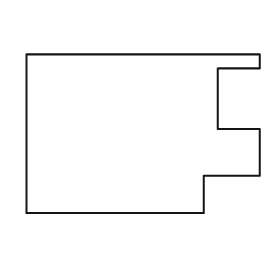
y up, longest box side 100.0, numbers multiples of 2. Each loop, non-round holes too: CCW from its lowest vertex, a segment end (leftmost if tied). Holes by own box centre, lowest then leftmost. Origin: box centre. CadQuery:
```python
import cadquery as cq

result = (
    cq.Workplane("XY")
    .moveTo(-50.0, -34.0)
    .lineTo(26.0, -34.0)
    .lineTo(26.0, -18.0)
    .lineTo(50.0, -18.0)
    .lineTo(50.0, 2.0)
    .lineTo(32.0, 2.0)
    .lineTo(32.0, 28.0)
    .lineTo(50.0, 28.0)
    .lineTo(50.0, 34.0)
    .lineTo(-50.0, 34.0)
    .close()
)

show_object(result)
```